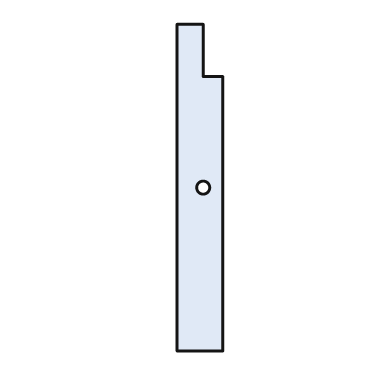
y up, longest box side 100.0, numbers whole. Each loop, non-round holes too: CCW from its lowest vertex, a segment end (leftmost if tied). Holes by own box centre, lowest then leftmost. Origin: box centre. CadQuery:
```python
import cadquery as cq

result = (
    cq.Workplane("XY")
    .moveTo(-7.0, -50.0)
    .lineTo(7.0, -50.0)
    .lineTo(7.0, 34.0)
    .lineTo(1.0, 34.0)
    .lineTo(1.0, 50.0)
    .lineTo(-7.0, 50.0)
    .close()
    .moveTo(1.0, 0.0)
    .circle(2.0)
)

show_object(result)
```